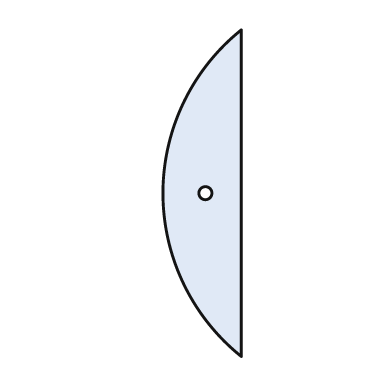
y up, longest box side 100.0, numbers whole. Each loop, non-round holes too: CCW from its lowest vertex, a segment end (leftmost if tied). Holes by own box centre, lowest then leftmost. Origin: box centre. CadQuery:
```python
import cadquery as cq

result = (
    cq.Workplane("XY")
    .moveTo(12.0, -50.0)
    .lineTo(12.0, 50.0)
    .threePointArc((-12.0, 0.0), (12.0, -50.0))
    .close()
    .moveTo(1.0, 0.0)
    .circle(2.0)
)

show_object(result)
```